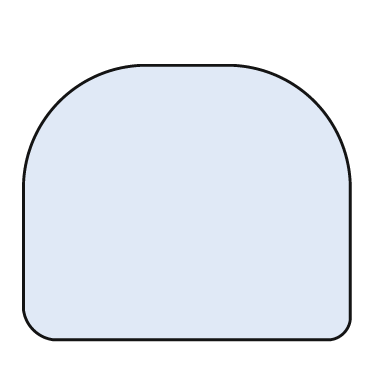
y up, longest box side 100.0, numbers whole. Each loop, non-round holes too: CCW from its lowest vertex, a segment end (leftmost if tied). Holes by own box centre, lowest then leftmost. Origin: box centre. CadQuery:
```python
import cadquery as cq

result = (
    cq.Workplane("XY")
    .moveTo(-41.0, -42.0)
    .lineTo(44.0, -42.0)
    .threePointArc((48.0, -40.0), (50.0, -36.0))
    .lineTo(50.0, 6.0)
    .threePointArc((39.0, 31.0), (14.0, 42.0))
    .lineTo(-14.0, 42.0)
    .threePointArc((-39.0, 31.0), (-50.0, 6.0))
    .lineTo(-50.0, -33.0)
    .threePointArc((-47.0, -39.0), (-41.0, -42.0))
    .close()
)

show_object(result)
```